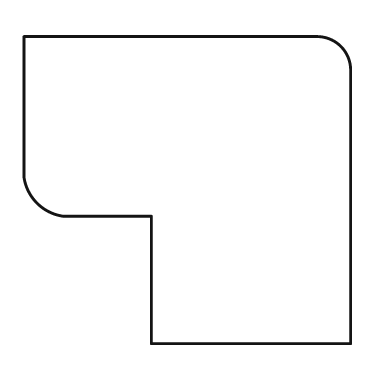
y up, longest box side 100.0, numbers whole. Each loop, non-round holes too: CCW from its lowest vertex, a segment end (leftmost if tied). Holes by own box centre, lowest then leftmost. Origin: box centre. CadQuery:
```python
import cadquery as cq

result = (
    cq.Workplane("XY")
    .moveTo(-11.0, -47.0)
    .lineTo(50.0, -47.0)
    .lineTo(50.0, 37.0)
    .threePointArc((47.0, 44.0), (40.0, 47.0))
    .lineTo(-50.0, 47.0)
    .lineTo(-50.0, 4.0)
    .threePointArc((-46.0, -4.0), (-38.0, -8.0))
    .lineTo(-11.0, -8.0)
    .close()
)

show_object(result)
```